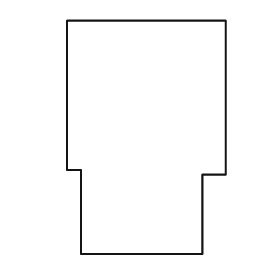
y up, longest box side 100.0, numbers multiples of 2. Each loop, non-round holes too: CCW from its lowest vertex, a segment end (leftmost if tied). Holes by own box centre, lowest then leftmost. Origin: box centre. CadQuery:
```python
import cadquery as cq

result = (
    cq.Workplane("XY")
    .moveTo(-28.0, -50.0)
    .lineTo(24.0, -50.0)
    .lineTo(24.0, -16.0)
    .lineTo(34.0, -16.0)
    .lineTo(34.0, 50.0)
    .lineTo(-34.0, 50.0)
    .lineTo(-34.0, -14.0)
    .lineTo(-28.0, -14.0)
    .close()
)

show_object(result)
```